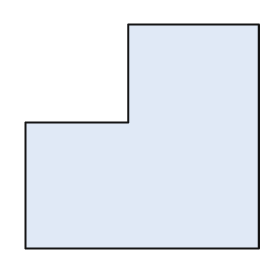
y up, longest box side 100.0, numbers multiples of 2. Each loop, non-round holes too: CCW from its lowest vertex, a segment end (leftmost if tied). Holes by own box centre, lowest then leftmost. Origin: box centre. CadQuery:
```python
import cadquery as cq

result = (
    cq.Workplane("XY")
    .moveTo(-50.0, -48.0)
    .lineTo(50.0, -48.0)
    .lineTo(50.0, 48.0)
    .lineTo(-6.0, 48.0)
    .lineTo(-6.0, 6.0)
    .lineTo(-50.0, 6.0)
    .close()
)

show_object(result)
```